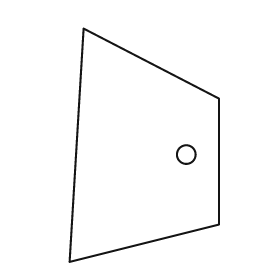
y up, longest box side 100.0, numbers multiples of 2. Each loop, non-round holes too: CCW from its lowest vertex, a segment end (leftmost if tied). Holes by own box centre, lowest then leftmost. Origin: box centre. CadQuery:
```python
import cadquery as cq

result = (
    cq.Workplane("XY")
    .moveTo(-32.0, -50.0)
    .lineTo(32.0, -34.0)
    .lineTo(32.0, 20.0)
    .lineTo(-26.0, 50.0)
    .close()
    .moveTo(18.0, -4.0)
    .circle(4.0)
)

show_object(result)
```